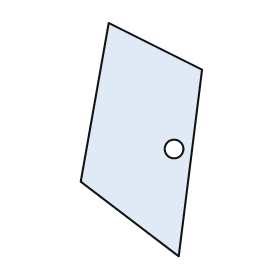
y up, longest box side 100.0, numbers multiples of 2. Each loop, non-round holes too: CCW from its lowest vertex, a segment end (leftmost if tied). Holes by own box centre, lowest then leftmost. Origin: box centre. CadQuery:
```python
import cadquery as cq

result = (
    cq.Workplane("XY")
    .moveTo(16.0, -50.0)
    .lineTo(26.0, 30.0)
    .lineTo(-14.0, 50.0)
    .lineTo(-26.0, -18.0)
    .close()
    .moveTo(14.0, -4.0)
    .circle(4.0)
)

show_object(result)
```